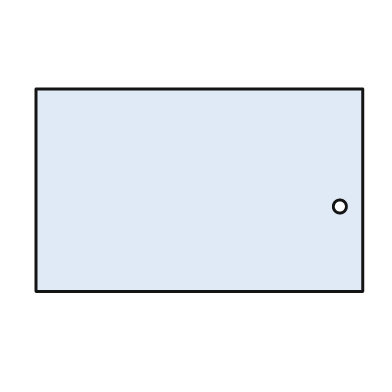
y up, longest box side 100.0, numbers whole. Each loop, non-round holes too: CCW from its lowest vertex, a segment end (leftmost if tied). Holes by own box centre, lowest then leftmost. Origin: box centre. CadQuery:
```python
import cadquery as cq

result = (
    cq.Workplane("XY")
    .moveTo(-50.0, -31.0)
    .lineTo(50.0, -31.0)
    .lineTo(50.0, 31.0)
    .lineTo(-50.0, 31.0)
    .close()
    .moveTo(43.0, -5.0)
    .circle(2.0)
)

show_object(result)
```